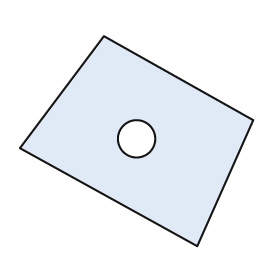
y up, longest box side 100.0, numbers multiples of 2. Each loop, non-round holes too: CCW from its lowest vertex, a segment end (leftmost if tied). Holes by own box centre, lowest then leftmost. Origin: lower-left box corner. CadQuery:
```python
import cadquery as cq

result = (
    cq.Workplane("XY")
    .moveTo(76.0, 0.0)
    .lineTo(100.0, 54.0)
    .lineTo(36.0, 90.0)
    .lineTo(0.0, 42.0)
    .close()
    .moveTo(50.0, 46.0)
    .circle(8.0)
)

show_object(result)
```